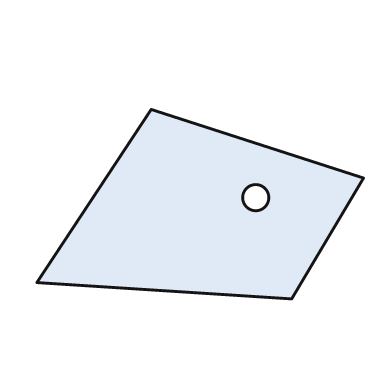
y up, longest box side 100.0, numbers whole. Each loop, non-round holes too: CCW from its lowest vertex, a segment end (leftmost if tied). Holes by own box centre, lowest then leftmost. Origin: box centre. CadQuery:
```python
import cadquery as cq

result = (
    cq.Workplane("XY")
    .moveTo(28.0, -29.0)
    .lineTo(50.0, 8.0)
    .lineTo(-15.0, 29.0)
    .lineTo(-50.0, -24.0)
    .close()
    .moveTo(17.0, 2.0)
    .circle(4.0)
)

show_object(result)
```